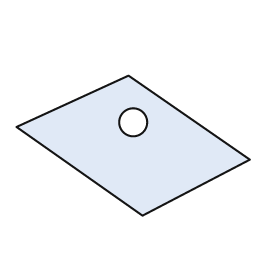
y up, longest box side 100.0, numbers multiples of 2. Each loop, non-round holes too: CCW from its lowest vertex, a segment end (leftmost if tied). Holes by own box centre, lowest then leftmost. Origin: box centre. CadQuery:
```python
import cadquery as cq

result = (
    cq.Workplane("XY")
    .moveTo(4.0, -30.0)
    .lineTo(50.0, -6.0)
    .lineTo(-2.0, 30.0)
    .lineTo(-50.0, 8.0)
    .close()
    .moveTo(0.0, 10.0)
    .circle(6.0)
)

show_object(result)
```